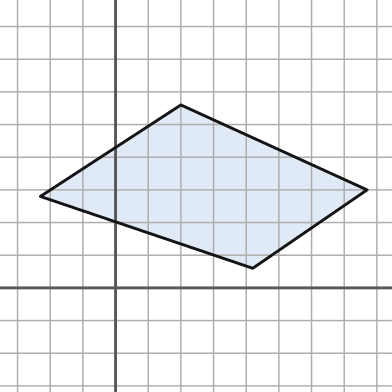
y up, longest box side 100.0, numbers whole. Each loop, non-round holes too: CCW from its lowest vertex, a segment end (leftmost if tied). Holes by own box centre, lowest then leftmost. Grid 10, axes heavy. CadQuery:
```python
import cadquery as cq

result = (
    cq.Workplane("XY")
    .moveTo(42.0, 6.0)
    .lineTo(77.0, 30.0)
    .lineTo(20.0, 56.0)
    .lineTo(-23.0, 28.0)
    .close()
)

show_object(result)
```